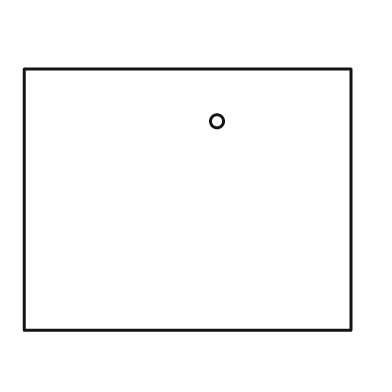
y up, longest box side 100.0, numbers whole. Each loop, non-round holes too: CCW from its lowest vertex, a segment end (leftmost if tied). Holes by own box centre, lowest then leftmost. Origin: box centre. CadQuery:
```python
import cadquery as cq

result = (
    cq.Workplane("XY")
    .moveTo(-50.0, -40.0)
    .lineTo(50.0, -40.0)
    .lineTo(50.0, 40.0)
    .lineTo(-50.0, 40.0)
    .close()
    .moveTo(9.0, 24.0)
    .circle(2.0)
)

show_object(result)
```